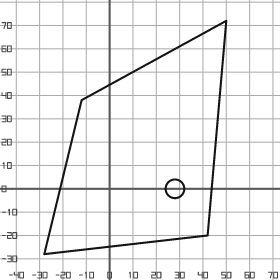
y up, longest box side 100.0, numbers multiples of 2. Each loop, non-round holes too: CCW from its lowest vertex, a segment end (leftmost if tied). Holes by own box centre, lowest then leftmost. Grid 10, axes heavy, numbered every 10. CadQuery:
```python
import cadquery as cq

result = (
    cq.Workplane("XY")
    .moveTo(-28.0, -28.0)
    .lineTo(42.0, -20.0)
    .lineTo(50.0, 72.0)
    .lineTo(-12.0, 38.0)
    .close()
    .moveTo(28.0, 0.0)
    .circle(4.0)
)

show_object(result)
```